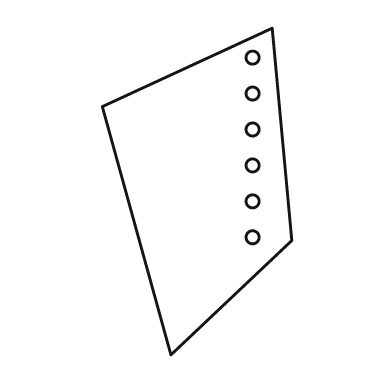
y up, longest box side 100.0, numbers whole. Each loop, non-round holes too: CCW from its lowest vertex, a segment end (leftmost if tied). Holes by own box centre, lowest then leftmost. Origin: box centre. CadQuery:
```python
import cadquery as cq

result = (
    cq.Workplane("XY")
    .moveTo(-8.0, -50.0)
    .lineTo(29.0, -15.0)
    .lineTo(23.0, 50.0)
    .lineTo(-29.0, 26.0)
    .close()
    .moveTo(17.0, -14.0)
    .circle(2.0)
    .moveTo(17.0, -3.0)
    .circle(2.0)
    .moveTo(17.0, 8.0)
    .circle(2.0)
    .moveTo(17.0, 19.0)
    .circle(2.0)
    .moveTo(17.0, 30.0)
    .circle(2.0)
    .moveTo(17.0, 41.0)
    .circle(2.0)
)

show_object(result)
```